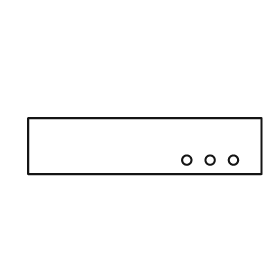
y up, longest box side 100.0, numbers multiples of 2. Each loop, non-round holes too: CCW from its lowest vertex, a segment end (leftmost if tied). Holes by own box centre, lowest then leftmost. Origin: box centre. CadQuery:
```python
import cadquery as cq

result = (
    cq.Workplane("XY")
    .moveTo(-50.0, -12.0)
    .lineTo(50.0, -12.0)
    .lineTo(50.0, 12.0)
    .lineTo(-50.0, 12.0)
    .close()
    .moveTo(18.0, -6.0)
    .circle(2.0)
    .moveTo(28.0, -6.0)
    .circle(2.0)
    .moveTo(38.0, -6.0)
    .circle(2.0)
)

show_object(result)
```